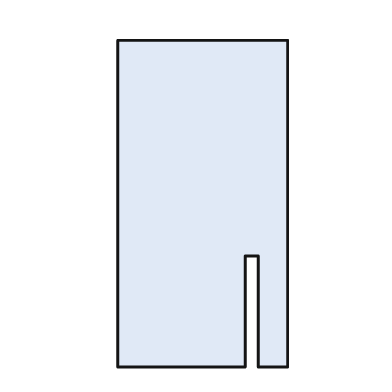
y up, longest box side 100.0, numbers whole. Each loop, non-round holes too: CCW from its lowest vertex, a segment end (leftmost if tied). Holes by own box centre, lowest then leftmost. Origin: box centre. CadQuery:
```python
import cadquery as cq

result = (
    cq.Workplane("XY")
    .moveTo(-26.0, -50.0)
    .lineTo(13.0, -50.0)
    .lineTo(13.0, -16.0)
    .lineTo(17.0, -16.0)
    .lineTo(17.0, -50.0)
    .lineTo(26.0, -50.0)
    .lineTo(26.0, 50.0)
    .lineTo(-26.0, 50.0)
    .close()
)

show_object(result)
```